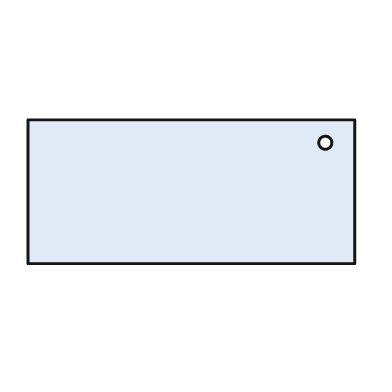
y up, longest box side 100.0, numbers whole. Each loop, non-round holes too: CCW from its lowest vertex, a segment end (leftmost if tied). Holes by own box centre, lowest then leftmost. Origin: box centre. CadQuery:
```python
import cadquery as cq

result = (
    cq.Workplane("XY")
    .moveTo(-50.0, -22.0)
    .lineTo(50.0, -22.0)
    .lineTo(50.0, 22.0)
    .lineTo(-50.0, 22.0)
    .close()
    .moveTo(41.0, 15.0)
    .circle(2.0)
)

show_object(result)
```